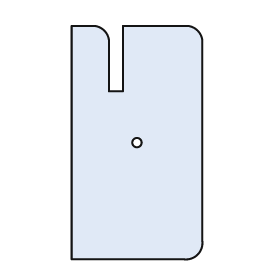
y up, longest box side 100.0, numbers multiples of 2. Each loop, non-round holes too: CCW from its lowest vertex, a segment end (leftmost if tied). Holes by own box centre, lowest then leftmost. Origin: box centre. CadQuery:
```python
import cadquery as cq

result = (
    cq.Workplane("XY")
    .moveTo(-28.0, -50.0)
    .lineTo(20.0, -50.0)
    .threePointArc((26.0, -48.0), (28.0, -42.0))
    .lineTo(28.0, 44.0)
    .threePointArc((26.0, 48.0), (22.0, 50.0))
    .lineTo(-6.0, 50.0)
    .lineTo(-6.0, 22.0)
    .lineTo(-12.0, 22.0)
    .lineTo(-12.0, 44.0)
    .threePointArc((-14.0, 48.0), (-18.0, 50.0))
    .lineTo(-28.0, 50.0)
    .close()
    .moveTo(0.0, 0.0)
    .circle(2.0)
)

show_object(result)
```